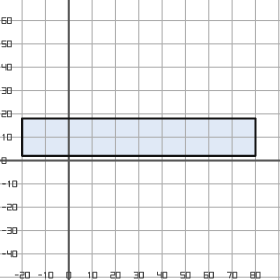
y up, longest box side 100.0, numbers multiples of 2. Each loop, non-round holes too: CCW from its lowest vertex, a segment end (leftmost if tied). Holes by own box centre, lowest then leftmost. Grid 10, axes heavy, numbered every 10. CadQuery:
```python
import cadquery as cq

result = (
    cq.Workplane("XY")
    .moveTo(-20.0, 2.0)
    .lineTo(80.0, 2.0)
    .lineTo(80.0, 18.0)
    .lineTo(-20.0, 18.0)
    .close()
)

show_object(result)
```